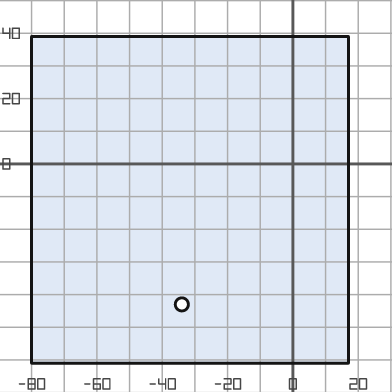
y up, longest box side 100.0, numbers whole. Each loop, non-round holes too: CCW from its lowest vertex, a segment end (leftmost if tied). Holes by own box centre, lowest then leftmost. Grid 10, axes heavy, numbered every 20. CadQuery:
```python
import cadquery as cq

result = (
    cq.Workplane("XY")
    .moveTo(-80.0, -61.0)
    .lineTo(17.0, -61.0)
    .lineTo(17.0, 39.0)
    .lineTo(-80.0, 39.0)
    .close()
    .moveTo(-34.0, -43.0)
    .circle(2.0)
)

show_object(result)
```